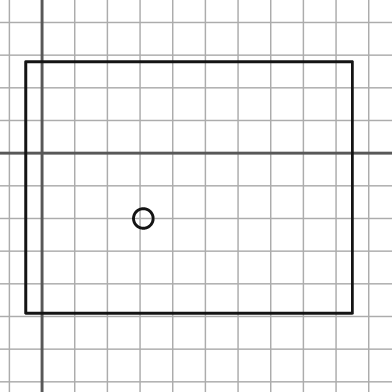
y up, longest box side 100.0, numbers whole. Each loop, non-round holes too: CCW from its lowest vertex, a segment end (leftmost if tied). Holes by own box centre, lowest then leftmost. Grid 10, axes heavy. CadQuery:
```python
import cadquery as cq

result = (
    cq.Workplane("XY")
    .moveTo(-5.0, -49.0)
    .lineTo(95.0, -49.0)
    .lineTo(95.0, 28.0)
    .lineTo(-5.0, 28.0)
    .close()
    .moveTo(31.0, -20.0)
    .circle(3.0)
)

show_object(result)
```